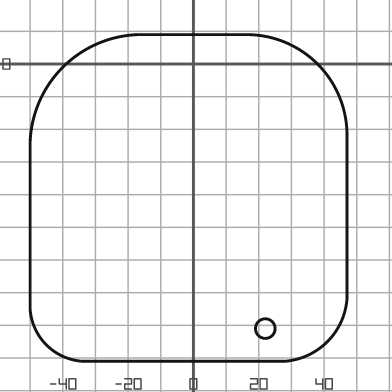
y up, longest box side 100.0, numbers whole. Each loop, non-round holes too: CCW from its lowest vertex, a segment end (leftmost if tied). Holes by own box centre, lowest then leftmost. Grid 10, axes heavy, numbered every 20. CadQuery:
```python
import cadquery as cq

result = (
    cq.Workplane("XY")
    .moveTo(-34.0, -91.0)
    .lineTo(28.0, -91.0)
    .threePointArc((41.0, -85.0), (47.0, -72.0))
    .lineTo(47.0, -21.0)
    .threePointArc((38.0, 0.0), (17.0, 9.0))
    .lineTo(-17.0, 9.0)
    .threePointArc((-40.0, -1.0), (-50.0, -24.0))
    .lineTo(-50.0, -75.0)
    .threePointArc((-45.0, -86.0), (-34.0, -91.0))
    .close()
    .moveTo(22.0, -81.0)
    .circle(3.0)
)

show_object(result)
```